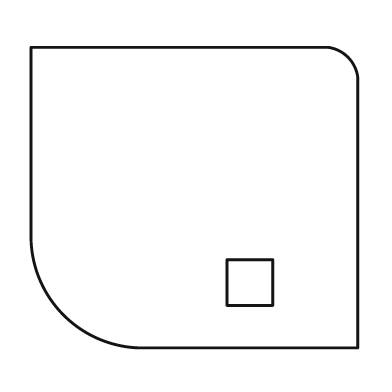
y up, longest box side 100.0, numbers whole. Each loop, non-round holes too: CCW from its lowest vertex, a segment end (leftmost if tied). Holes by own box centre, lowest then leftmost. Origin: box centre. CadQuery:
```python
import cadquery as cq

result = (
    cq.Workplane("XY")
    .moveTo(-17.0, -46.0)
    .lineTo(50.0, -46.0)
    .lineTo(50.0, 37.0)
    .threePointArc((47.0, 43.0), (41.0, 46.0))
    .lineTo(-50.0, 46.0)
    .lineTo(-50.0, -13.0)
    .threePointArc((-40.0, -36.0), (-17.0, -46.0))
    .close()
    .moveTo(10.0, -33.0)
    .lineTo(24.0, -33.0)
    .lineTo(24.0, -19.0)
    .lineTo(10.0, -19.0)
    .close()
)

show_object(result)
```